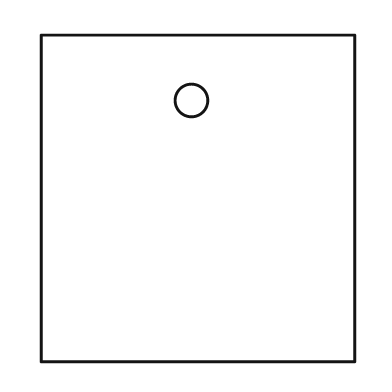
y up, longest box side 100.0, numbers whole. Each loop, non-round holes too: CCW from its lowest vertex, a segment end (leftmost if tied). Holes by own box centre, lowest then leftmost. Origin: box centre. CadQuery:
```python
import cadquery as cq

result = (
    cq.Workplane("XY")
    .moveTo(-48.0, -50.0)
    .lineTo(48.0, -50.0)
    .lineTo(48.0, 50.0)
    .lineTo(-48.0, 50.0)
    .close()
    .moveTo(-2.0, 30.0)
    .circle(5.0)
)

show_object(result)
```